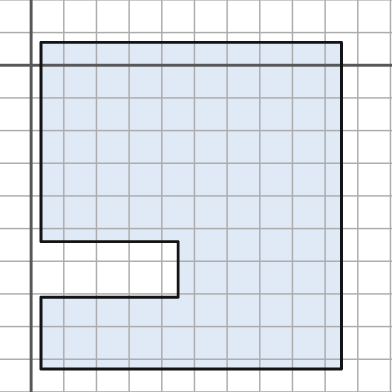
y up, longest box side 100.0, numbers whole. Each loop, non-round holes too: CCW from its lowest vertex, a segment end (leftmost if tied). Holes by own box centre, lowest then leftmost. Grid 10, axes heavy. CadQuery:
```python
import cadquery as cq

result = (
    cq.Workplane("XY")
    .moveTo(3.0, -93.0)
    .lineTo(95.0, -93.0)
    .lineTo(95.0, 7.0)
    .lineTo(3.0, 7.0)
    .lineTo(3.0, -54.0)
    .lineTo(45.0, -54.0)
    .lineTo(45.0, -71.0)
    .lineTo(3.0, -71.0)
    .close()
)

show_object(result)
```